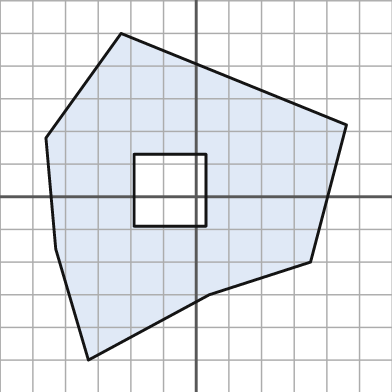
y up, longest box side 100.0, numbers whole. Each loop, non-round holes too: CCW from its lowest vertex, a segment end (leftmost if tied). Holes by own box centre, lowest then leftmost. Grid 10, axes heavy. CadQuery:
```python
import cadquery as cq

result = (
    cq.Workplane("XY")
    .moveTo(-33.0, -50.0)
    .lineTo(4.0, -30.0)
    .lineTo(35.0, -20.0)
    .lineTo(46.0, 22.0)
    .lineTo(-23.0, 50.0)
    .lineTo(-46.0, 18.0)
    .lineTo(-43.0, -16.0)
    .close()
    .moveTo(-19.0, -9.0)
    .lineTo(3.0, -9.0)
    .lineTo(3.0, 13.0)
    .lineTo(-19.0, 13.0)
    .close()
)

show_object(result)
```